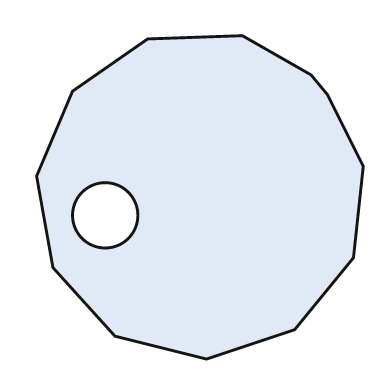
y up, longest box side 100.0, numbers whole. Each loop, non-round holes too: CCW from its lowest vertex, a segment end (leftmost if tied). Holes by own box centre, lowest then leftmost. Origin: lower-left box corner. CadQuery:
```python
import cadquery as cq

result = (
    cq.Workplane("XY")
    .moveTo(52.0, 0.0)
    .lineTo(79.0, 9.0)
    .lineTo(97.0, 31.0)
    .lineTo(100.0, 59.0)
    .lineTo(89.0, 81.0)
    .lineTo(84.0, 87.0)
    .lineTo(63.0, 99.0)
    .lineTo(34.0, 98.0)
    .lineTo(11.0, 82.0)
    .lineTo(0.0, 56.0)
    .lineTo(5.0, 28.0)
    .lineTo(24.0, 7.0)
    .close()
    .moveTo(21.0, 44.0)
    .circle(10.0)
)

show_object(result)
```